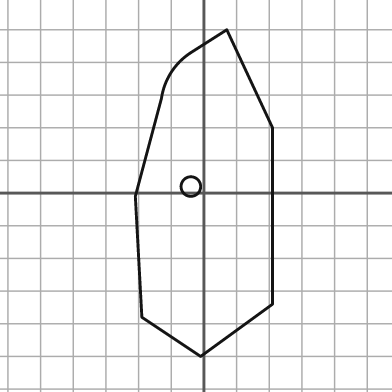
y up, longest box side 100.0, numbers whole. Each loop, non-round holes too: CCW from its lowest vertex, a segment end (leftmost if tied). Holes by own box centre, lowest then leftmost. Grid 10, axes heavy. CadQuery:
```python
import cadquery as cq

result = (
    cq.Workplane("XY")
    .moveTo(-1.0, -50.0)
    .lineTo(21.0, -34.0)
    .lineTo(21.0, 20.0)
    .lineTo(7.0, 50.0)
    .lineTo(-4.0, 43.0)
    .threePointArc((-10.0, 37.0), (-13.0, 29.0))
    .lineTo(-21.0, -1.0)
    .lineTo(-19.0, -38.0)
    .close()
    .moveTo(-4.0, 2.0)
    .circle(3.0)
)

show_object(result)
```